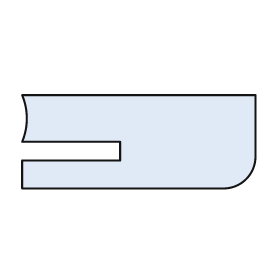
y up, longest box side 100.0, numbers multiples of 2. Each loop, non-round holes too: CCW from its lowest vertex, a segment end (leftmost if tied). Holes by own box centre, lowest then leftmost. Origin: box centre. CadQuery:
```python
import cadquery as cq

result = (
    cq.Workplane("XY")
    .moveTo(-50.0, -20.0)
    .lineTo(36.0, -20.0)
    .threePointArc((46.0, -16.0), (50.0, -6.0))
    .lineTo(50.0, 20.0)
    .lineTo(-50.0, 20.0)
    .threePointArc((-48.0, 10.0), (-50.0, 0.0))
    .lineTo(-8.0, 0.0)
    .lineTo(-8.0, -8.0)
    .lineTo(-50.0, -8.0)
    .close()
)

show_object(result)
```